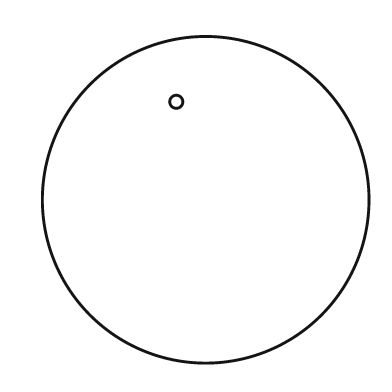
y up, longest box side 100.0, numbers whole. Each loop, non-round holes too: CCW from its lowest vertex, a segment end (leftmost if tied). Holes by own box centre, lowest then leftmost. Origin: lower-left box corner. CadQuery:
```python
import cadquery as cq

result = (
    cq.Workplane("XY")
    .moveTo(50.0, 50.0)
    .circle(50.0)
    .moveTo(41.0, 80.0)
    .circle(2.0)
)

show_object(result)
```